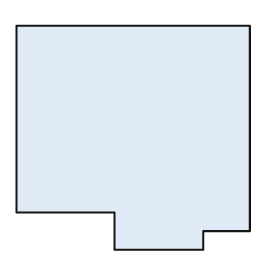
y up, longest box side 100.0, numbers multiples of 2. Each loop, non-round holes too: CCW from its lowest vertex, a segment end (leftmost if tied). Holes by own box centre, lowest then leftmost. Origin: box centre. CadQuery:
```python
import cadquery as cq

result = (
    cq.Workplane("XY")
    .moveTo(-8.0, -48.0)
    .lineTo(30.0, -48.0)
    .lineTo(30.0, -40.0)
    .lineTo(50.0, -40.0)
    .lineTo(50.0, 48.0)
    .lineTo(-50.0, 48.0)
    .lineTo(-50.0, -32.0)
    .lineTo(-8.0, -32.0)
    .close()
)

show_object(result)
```